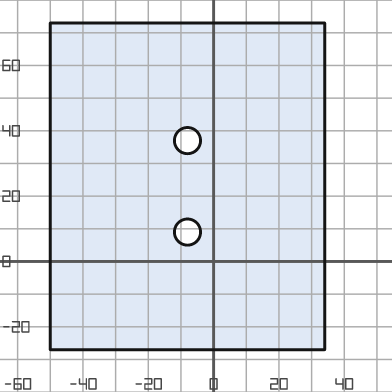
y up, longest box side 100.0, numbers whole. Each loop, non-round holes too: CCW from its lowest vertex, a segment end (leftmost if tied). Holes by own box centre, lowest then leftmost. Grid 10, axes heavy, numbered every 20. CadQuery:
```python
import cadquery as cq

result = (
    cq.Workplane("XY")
    .moveTo(-50.0, -27.0)
    .lineTo(34.0, -27.0)
    .lineTo(34.0, 73.0)
    .lineTo(-50.0, 73.0)
    .close()
    .moveTo(-8.0, 9.0)
    .circle(4.0)
    .moveTo(-8.0, 37.0)
    .circle(4.0)
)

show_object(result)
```